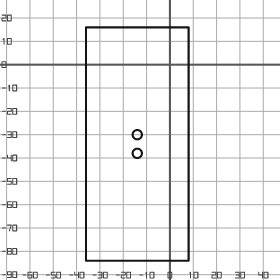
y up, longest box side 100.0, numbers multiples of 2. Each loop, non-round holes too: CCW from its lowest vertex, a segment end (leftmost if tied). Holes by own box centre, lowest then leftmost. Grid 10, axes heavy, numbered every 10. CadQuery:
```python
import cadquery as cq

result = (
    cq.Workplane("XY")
    .moveTo(-36.0, -84.0)
    .lineTo(8.0, -84.0)
    .lineTo(8.0, 16.0)
    .lineTo(-36.0, 16.0)
    .close()
    .moveTo(-14.0, -38.0)
    .circle(2.0)
    .moveTo(-14.0, -30.0)
    .circle(2.0)
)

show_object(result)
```